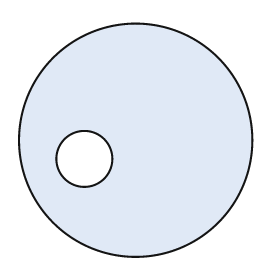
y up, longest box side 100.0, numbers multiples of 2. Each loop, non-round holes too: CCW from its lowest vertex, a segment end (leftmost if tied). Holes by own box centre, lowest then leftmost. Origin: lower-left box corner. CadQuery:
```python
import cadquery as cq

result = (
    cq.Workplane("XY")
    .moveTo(50.0, 50.0)
    .circle(50.0)
    .moveTo(28.0, 42.0)
    .circle(12.0)
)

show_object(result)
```